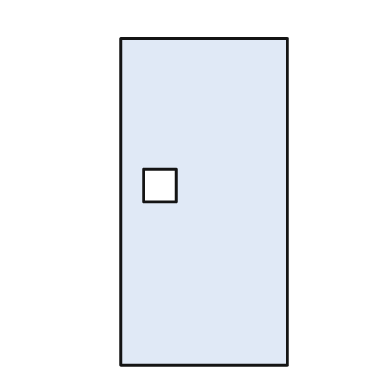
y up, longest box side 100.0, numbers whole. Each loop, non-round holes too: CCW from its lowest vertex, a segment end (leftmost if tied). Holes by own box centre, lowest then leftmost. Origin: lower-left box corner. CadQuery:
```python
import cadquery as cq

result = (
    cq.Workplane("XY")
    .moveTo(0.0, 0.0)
    .lineTo(51.0, 0.0)
    .lineTo(51.0, 100.0)
    .lineTo(0.0, 100.0)
    .close()
    .moveTo(7.0, 50.0)
    .lineTo(17.0, 50.0)
    .lineTo(17.0, 60.0)
    .lineTo(7.0, 60.0)
    .close()
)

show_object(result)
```